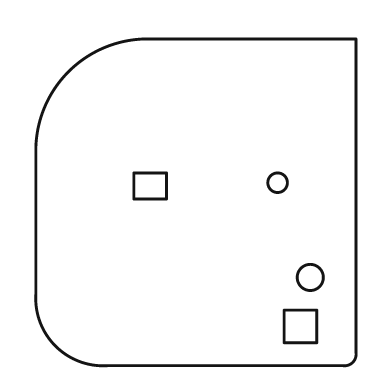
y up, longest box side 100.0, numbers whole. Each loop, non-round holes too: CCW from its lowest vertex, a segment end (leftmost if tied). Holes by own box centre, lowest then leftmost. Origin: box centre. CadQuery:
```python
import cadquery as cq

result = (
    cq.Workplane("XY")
    .moveTo(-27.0, -50.0)
    .lineTo(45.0, -50.0)
    .threePointArc((48.0, -49.0), (49.0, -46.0))
    .lineTo(49.0, 50.0)
    .lineTo(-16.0, 50.0)
    .threePointArc((-39.0, 40.0), (-49.0, 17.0))
    .lineTo(-49.0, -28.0)
    .threePointArc((-43.0, -44.0), (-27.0, -50.0))
    .close()
    .moveTo(27.0, -43.0)
    .lineTo(37.0, -43.0)
    .lineTo(37.0, -33.0)
    .lineTo(27.0, -33.0)
    .close()
    .moveTo(35.0, -23.0)
    .circle(4.0)
    .moveTo(-19.0, 1.0)
    .lineTo(-9.0, 1.0)
    .lineTo(-9.0, 9.0)
    .lineTo(-19.0, 9.0)
    .close()
    .moveTo(25.0, 6.0)
    .circle(3.0)
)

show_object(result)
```